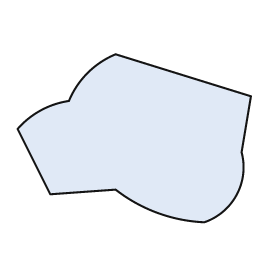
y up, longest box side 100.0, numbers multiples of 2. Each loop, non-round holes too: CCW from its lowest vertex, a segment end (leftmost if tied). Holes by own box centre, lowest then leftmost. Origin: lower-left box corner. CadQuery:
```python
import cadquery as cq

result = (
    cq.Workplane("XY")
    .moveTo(80.0, 0.0)
    .threePointArc((94.0, 12.0), (96.0, 30.0))
    .lineTo(100.0, 54.0)
    .lineTo(42.0, 72.0)
    .threePointArc((30.0, 64.0), (22.0, 52.0))
    .threePointArc((10.0, 48.0), (0.0, 40.0))
    .lineTo(14.0, 12.0)
    .lineTo(42.0, 14.0)
    .threePointArc((60.0, 4.0), (80.0, 0.0))
    .close()
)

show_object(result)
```